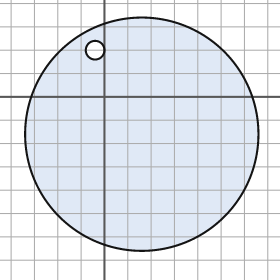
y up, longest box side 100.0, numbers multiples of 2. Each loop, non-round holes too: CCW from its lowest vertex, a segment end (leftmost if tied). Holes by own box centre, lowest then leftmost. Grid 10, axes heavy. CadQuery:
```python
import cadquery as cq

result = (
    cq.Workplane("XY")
    .moveTo(16.0, -16.0)
    .circle(50.0)
    .moveTo(-4.0, 20.0)
    .circle(4.0)
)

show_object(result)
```